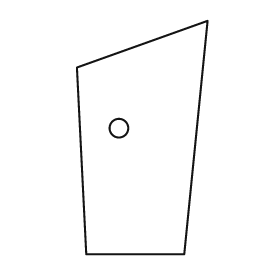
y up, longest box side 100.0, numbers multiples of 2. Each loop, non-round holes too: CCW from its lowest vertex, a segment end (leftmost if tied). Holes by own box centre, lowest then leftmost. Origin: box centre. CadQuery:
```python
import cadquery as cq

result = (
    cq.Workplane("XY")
    .moveTo(-24.0, -50.0)
    .lineTo(18.0, -50.0)
    .lineTo(28.0, 50.0)
    .lineTo(-28.0, 30.0)
    .close()
    .moveTo(-10.0, 4.0)
    .circle(4.0)
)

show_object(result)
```